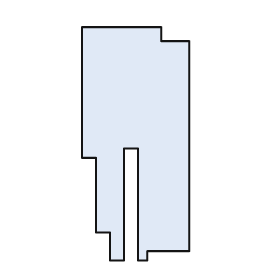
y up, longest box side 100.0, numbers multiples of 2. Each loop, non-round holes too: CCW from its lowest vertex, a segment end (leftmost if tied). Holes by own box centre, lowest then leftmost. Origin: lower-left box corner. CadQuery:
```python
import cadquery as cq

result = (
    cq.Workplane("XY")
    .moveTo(12.0, 0.0)
    .lineTo(18.0, 0.0)
    .lineTo(18.0, 48.0)
    .lineTo(24.0, 48.0)
    .lineTo(24.0, 0.0)
    .lineTo(28.0, 0.0)
    .lineTo(28.0, 4.0)
    .lineTo(46.0, 4.0)
    .lineTo(46.0, 94.0)
    .lineTo(34.0, 94.0)
    .lineTo(34.0, 100.0)
    .lineTo(0.0, 100.0)
    .lineTo(0.0, 44.0)
    .lineTo(6.0, 44.0)
    .lineTo(6.0, 12.0)
    .lineTo(12.0, 12.0)
    .close()
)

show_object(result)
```